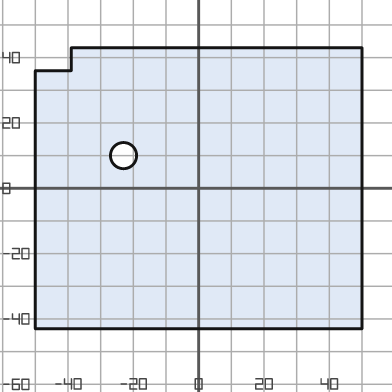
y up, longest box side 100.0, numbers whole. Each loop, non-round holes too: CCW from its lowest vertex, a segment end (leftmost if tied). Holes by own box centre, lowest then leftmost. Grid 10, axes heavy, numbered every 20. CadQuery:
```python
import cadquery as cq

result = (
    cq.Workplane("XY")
    .moveTo(-50.0, -43.0)
    .lineTo(50.0, -43.0)
    .lineTo(50.0, 43.0)
    .lineTo(-39.0, 43.0)
    .lineTo(-39.0, 36.0)
    .lineTo(-50.0, 36.0)
    .close()
    .moveTo(-23.0, 10.0)
    .circle(4.0)
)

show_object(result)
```